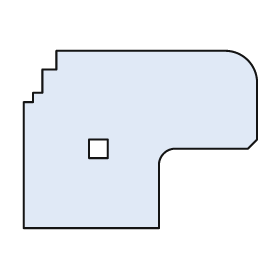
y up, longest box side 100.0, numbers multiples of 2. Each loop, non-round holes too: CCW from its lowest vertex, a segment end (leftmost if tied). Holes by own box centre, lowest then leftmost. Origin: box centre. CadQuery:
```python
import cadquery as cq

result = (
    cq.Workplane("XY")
    .moveTo(-50.0, -38.0)
    .lineTo(8.0, -38.0)
    .lineTo(8.0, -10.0)
    .threePointArc((10.0, -6.0), (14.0, -4.0))
    .lineTo(46.0, -4.0)
    .lineTo(50.0, 0.0)
    .lineTo(50.0, 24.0)
    .threePointArc((46.0, 34.0), (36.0, 38.0))
    .lineTo(-36.0, 38.0)
    .lineTo(-36.0, 30.0)
    .lineTo(-42.0, 30.0)
    .lineTo(-42.0, 20.0)
    .lineTo(-46.0, 20.0)
    .lineTo(-46.0, 16.0)
    .lineTo(-50.0, 16.0)
    .close()
    .moveTo(-22.0, -8.0)
    .lineTo(-14.0, -8.0)
    .lineTo(-14.0, 0.0)
    .lineTo(-22.0, 0.0)
    .close()
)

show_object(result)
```